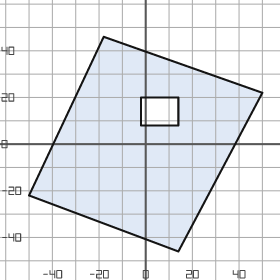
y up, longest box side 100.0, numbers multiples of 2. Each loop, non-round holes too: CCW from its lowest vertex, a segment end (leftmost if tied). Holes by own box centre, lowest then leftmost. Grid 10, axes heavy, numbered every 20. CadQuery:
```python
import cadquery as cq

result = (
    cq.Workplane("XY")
    .moveTo(14.0, -46.0)
    .lineTo(50.0, 22.0)
    .lineTo(-18.0, 46.0)
    .lineTo(-50.0, -22.0)
    .close()
    .moveTo(-2.0, 8.0)
    .lineTo(14.0, 8.0)
    .lineTo(14.0, 20.0)
    .lineTo(-2.0, 20.0)
    .close()
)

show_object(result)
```